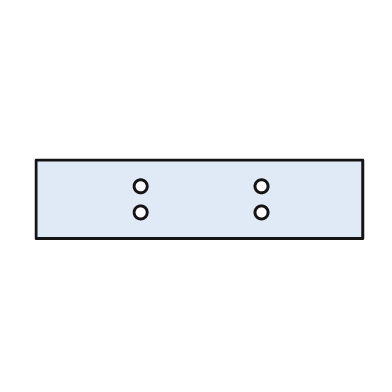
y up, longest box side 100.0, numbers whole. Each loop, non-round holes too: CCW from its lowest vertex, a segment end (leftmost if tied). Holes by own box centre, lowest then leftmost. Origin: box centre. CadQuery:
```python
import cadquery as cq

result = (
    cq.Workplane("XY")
    .moveTo(-50.0, -12.0)
    .lineTo(50.0, -12.0)
    .lineTo(50.0, 12.0)
    .lineTo(-50.0, 12.0)
    .close()
    .moveTo(-18.0, -4.0)
    .circle(2.0)
    .moveTo(19.0, -4.0)
    .circle(2.0)
    .moveTo(-18.0, 4.0)
    .circle(2.0)
    .moveTo(19.0, 4.0)
    .circle(2.0)
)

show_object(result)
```